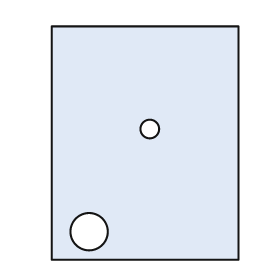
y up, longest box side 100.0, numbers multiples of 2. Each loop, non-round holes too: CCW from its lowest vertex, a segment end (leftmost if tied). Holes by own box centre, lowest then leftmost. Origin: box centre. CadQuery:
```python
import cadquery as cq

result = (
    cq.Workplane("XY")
    .moveTo(-40.0, -50.0)
    .lineTo(40.0, -50.0)
    .lineTo(40.0, 50.0)
    .lineTo(-40.0, 50.0)
    .close()
    .moveTo(-24.0, -38.0)
    .circle(8.0)
    .moveTo(2.0, 6.0)
    .circle(4.0)
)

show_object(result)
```